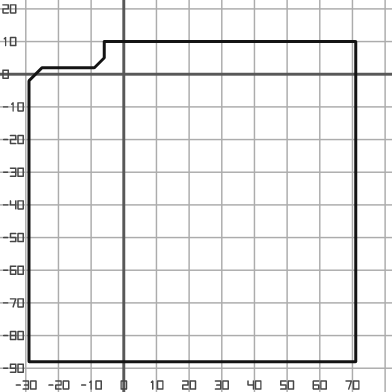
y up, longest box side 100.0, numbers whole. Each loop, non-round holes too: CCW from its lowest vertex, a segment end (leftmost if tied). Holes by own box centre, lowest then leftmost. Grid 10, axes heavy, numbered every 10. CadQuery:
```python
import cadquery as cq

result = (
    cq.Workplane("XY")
    .moveTo(-29.0, -88.0)
    .lineTo(71.0, -88.0)
    .lineTo(71.0, 10.0)
    .lineTo(-6.0, 10.0)
    .lineTo(-6.0, 5.0)
    .lineTo(-9.0, 2.0)
    .lineTo(-25.0, 2.0)
    .lineTo(-29.0, -2.0)
    .close()
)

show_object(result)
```